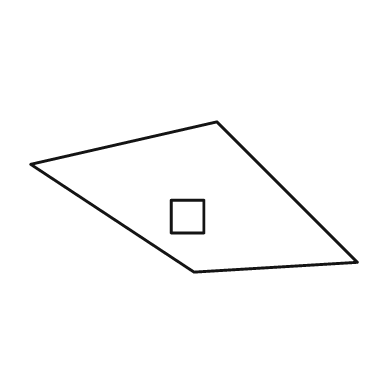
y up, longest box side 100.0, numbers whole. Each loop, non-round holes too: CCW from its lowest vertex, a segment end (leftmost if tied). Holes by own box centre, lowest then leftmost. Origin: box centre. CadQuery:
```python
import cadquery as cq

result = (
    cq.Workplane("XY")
    .moveTo(0.0, -23.0)
    .lineTo(50.0, -20.0)
    .lineTo(7.0, 23.0)
    .lineTo(-50.0, 10.0)
    .close()
    .moveTo(-7.0, -11.0)
    .lineTo(3.0, -11.0)
    .lineTo(3.0, -1.0)
    .lineTo(-7.0, -1.0)
    .close()
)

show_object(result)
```